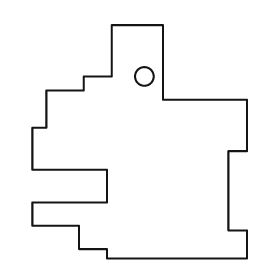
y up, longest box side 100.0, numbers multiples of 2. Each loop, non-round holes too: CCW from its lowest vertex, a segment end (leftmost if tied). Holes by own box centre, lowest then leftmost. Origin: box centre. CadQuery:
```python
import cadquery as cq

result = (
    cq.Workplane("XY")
    .moveTo(-14.0, -50.0)
    .lineTo(46.0, -50.0)
    .lineTo(46.0, -38.0)
    .lineTo(38.0, -38.0)
    .lineTo(38.0, -4.0)
    .lineTo(46.0, -4.0)
    .lineTo(46.0, 18.0)
    .lineTo(10.0, 18.0)
    .lineTo(10.0, 50.0)
    .lineTo(-12.0, 50.0)
    .lineTo(-12.0, 28.0)
    .lineTo(-24.0, 28.0)
    .lineTo(-24.0, 22.0)
    .lineTo(-40.0, 22.0)
    .lineTo(-40.0, 6.0)
    .lineTo(-46.0, 6.0)
    .lineTo(-46.0, -12.0)
    .lineTo(-14.0, -12.0)
    .lineTo(-14.0, -26.0)
    .lineTo(-46.0, -26.0)
    .lineTo(-46.0, -36.0)
    .lineTo(-26.0, -36.0)
    .lineTo(-26.0, -46.0)
    .lineTo(-14.0, -46.0)
    .close()
    .moveTo(2.0, 28.0)
    .circle(4.0)
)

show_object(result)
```